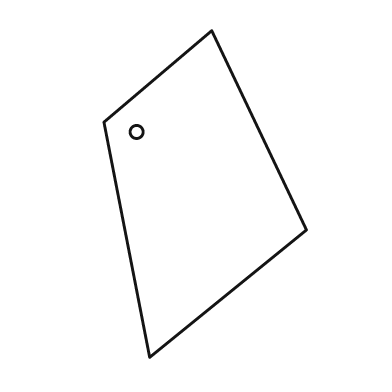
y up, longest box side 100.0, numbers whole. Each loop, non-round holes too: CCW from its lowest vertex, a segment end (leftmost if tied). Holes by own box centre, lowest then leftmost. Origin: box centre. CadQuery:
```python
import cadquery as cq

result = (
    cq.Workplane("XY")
    .moveTo(-17.0, -50.0)
    .lineTo(31.0, -11.0)
    .lineTo(2.0, 50.0)
    .lineTo(-31.0, 22.0)
    .close()
    .moveTo(-21.0, 19.0)
    .circle(2.0)
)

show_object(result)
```